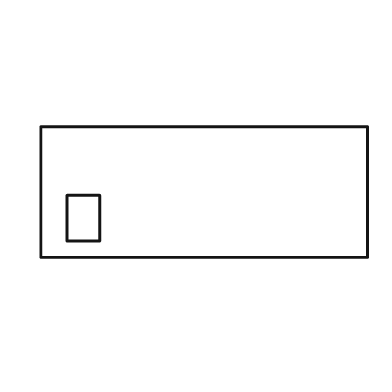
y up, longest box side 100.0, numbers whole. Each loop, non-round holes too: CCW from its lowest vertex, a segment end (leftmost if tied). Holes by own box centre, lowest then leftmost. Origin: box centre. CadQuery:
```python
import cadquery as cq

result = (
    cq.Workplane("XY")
    .moveTo(-50.0, -20.0)
    .lineTo(50.0, -20.0)
    .lineTo(50.0, 20.0)
    .lineTo(-50.0, 20.0)
    .close()
    .moveTo(-42.0, -15.0)
    .lineTo(-32.0, -15.0)
    .lineTo(-32.0, -1.0)
    .lineTo(-42.0, -1.0)
    .close()
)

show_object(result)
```